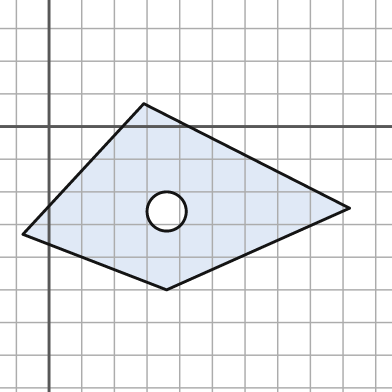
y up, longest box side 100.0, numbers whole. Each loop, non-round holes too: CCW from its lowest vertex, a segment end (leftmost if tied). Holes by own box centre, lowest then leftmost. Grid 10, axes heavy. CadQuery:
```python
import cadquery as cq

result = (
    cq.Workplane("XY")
    .moveTo(36.0, -50.0)
    .lineTo(92.0, -25.0)
    .lineTo(29.0, 7.0)
    .lineTo(-8.0, -33.0)
    .close()
    .moveTo(36.0, -26.0)
    .circle(6.0)
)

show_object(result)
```